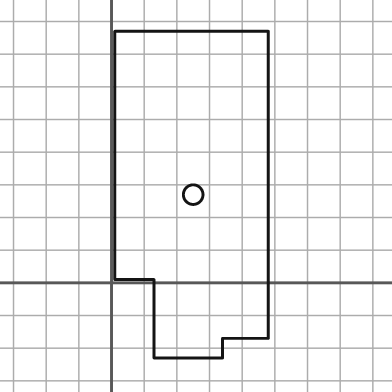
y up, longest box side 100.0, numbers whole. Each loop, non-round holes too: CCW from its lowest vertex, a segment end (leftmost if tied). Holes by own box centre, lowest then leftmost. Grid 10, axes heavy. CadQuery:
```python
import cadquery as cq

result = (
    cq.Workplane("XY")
    .moveTo(13.0, -23.0)
    .lineTo(34.0, -23.0)
    .lineTo(34.0, -17.0)
    .lineTo(48.0, -17.0)
    .lineTo(48.0, 77.0)
    .lineTo(1.0, 77.0)
    .lineTo(1.0, 1.0)
    .lineTo(13.0, 1.0)
    .close()
    .moveTo(25.0, 27.0)
    .circle(3.0)
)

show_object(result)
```